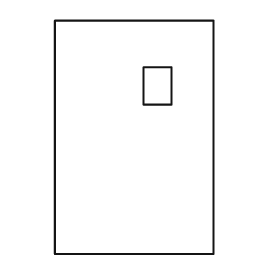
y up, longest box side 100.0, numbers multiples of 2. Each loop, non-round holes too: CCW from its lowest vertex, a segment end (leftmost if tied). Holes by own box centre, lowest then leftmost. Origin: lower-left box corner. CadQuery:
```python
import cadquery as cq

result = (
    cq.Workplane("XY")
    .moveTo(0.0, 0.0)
    .lineTo(68.0, 0.0)
    .lineTo(68.0, 100.0)
    .lineTo(0.0, 100.0)
    .close()
    .moveTo(38.0, 64.0)
    .lineTo(50.0, 64.0)
    .lineTo(50.0, 80.0)
    .lineTo(38.0, 80.0)
    .close()
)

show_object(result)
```